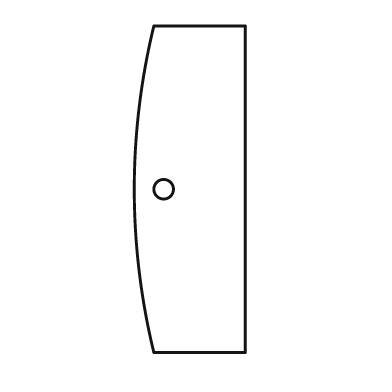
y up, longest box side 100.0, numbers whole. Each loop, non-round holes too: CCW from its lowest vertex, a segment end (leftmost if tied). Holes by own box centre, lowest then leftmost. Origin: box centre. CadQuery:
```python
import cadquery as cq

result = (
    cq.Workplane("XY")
    .moveTo(-11.0, -50.0)
    .lineTo(17.0, -50.0)
    .lineTo(17.0, 50.0)
    .lineTo(-11.0, 50.0)
    .threePointArc((-17.0, 0.0), (-11.0, -50.0))
    .close()
    .moveTo(-8.0, 0.0)
    .circle(3.0)
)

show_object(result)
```